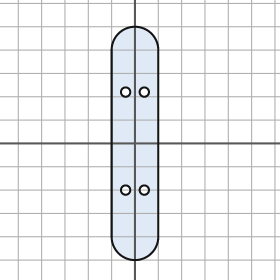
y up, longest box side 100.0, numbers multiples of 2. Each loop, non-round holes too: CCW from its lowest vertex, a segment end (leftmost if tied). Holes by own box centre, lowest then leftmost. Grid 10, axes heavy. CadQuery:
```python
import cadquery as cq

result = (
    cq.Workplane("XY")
    .moveTo(-10.0, -40.0)
    .threePointArc((0.0, -50.0), (10.0, -40.0))
    .lineTo(10.0, 40.0)
    .threePointArc((0.0, 50.0), (-10.0, 40.0))
    .close()
    .moveTo(-4.0, -20.0)
    .circle(2.0)
    .moveTo(4.0, -20.0)
    .circle(2.0)
    .moveTo(-4.0, 22.0)
    .circle(2.0)
    .moveTo(4.0, 22.0)
    .circle(2.0)
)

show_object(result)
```